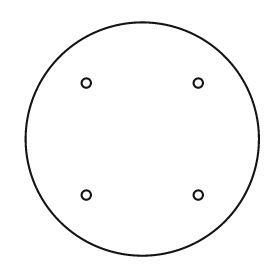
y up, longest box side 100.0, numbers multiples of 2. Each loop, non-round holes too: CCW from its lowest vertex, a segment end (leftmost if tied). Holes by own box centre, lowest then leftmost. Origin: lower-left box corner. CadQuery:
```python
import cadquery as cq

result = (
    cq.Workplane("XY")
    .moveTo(50.0, 50.0)
    .circle(50.0)
    .moveTo(26.0, 26.0)
    .circle(2.0)
    .moveTo(74.0, 26.0)
    .circle(2.0)
    .moveTo(26.0, 74.0)
    .circle(2.0)
    .moveTo(74.0, 74.0)
    .circle(2.0)
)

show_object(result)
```